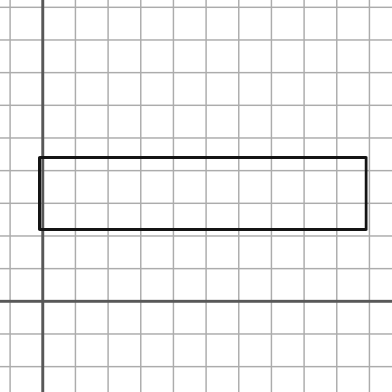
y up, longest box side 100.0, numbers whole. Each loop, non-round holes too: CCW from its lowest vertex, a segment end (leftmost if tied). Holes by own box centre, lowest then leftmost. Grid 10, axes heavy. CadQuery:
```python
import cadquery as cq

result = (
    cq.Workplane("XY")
    .moveTo(-1.0, 22.0)
    .lineTo(99.0, 22.0)
    .lineTo(99.0, 44.0)
    .lineTo(-1.0, 44.0)
    .close()
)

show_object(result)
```